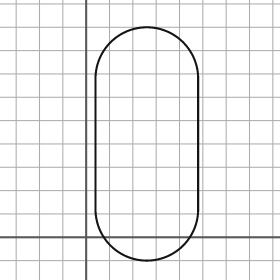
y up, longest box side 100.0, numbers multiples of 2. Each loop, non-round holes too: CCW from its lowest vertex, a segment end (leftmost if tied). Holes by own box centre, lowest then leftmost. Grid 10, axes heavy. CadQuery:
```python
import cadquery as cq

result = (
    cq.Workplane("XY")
    .moveTo(4.0, 12.0)
    .threePointArc((26.0, -10.0), (48.0, 12.0))
    .lineTo(48.0, 68.0)
    .threePointArc((26.0, 90.0), (4.0, 68.0))
    .close()
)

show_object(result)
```